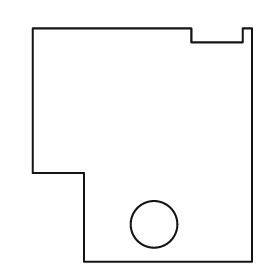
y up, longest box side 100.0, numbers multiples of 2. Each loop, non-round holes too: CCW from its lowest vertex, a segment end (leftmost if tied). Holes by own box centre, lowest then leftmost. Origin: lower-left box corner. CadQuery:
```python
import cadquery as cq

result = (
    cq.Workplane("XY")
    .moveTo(22.0, 0.0)
    .lineTo(94.0, 0.0)
    .lineTo(94.0, 100.0)
    .lineTo(90.0, 100.0)
    .lineTo(90.0, 94.0)
    .lineTo(68.0, 94.0)
    .lineTo(68.0, 100.0)
    .lineTo(0.0, 100.0)
    .lineTo(0.0, 38.0)
    .lineTo(22.0, 38.0)
    .close()
    .moveTo(52.0, 16.0)
    .circle(10.0)
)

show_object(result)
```